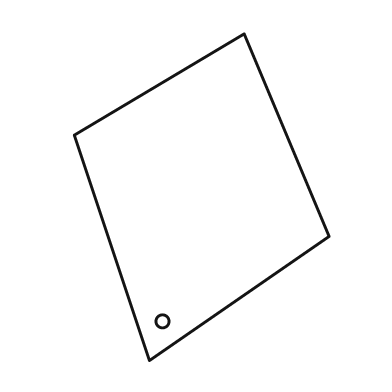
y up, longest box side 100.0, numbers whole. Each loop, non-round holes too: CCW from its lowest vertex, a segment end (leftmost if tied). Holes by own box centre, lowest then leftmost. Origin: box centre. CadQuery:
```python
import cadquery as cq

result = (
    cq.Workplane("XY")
    .moveTo(-16.0, -50.0)
    .lineTo(39.0, -12.0)
    .lineTo(13.0, 50.0)
    .lineTo(-39.0, 19.0)
    .close()
    .moveTo(-12.0, -38.0)
    .circle(2.0)
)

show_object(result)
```